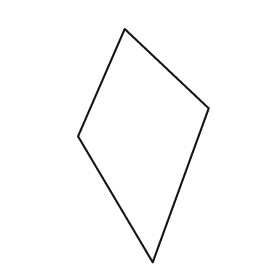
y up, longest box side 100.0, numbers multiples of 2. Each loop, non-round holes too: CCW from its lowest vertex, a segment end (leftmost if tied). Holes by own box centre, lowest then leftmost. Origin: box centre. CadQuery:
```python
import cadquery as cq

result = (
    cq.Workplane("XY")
    .moveTo(4.0, -50.0)
    .lineTo(28.0, 16.0)
    .lineTo(-8.0, 50.0)
    .lineTo(-28.0, 4.0)
    .close()
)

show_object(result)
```